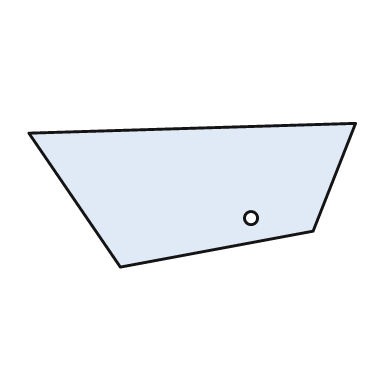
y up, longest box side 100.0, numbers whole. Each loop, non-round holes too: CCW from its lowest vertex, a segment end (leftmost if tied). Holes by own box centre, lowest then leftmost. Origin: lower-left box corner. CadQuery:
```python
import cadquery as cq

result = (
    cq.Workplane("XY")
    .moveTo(28.0, 0.0)
    .lineTo(87.0, 11.0)
    .lineTo(100.0, 44.0)
    .lineTo(0.0, 41.0)
    .close()
    .moveTo(68.0, 15.0)
    .circle(2.0)
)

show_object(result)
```